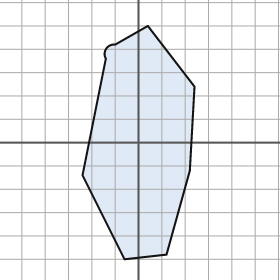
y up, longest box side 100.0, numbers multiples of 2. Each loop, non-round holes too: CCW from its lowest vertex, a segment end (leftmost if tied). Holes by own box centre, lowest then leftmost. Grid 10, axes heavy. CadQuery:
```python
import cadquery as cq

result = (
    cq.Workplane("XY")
    .moveTo(-6.0, -50.0)
    .lineTo(12.0, -48.0)
    .lineTo(22.0, -12.0)
    .lineTo(24.0, 24.0)
    .lineTo(4.0, 50.0)
    .lineTo(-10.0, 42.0)
    .threePointArc((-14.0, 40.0), (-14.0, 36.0))
    .lineTo(-24.0, -14.0)
    .close()
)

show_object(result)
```